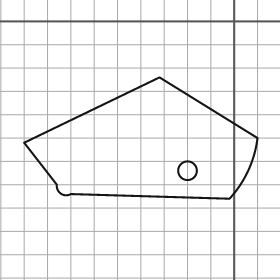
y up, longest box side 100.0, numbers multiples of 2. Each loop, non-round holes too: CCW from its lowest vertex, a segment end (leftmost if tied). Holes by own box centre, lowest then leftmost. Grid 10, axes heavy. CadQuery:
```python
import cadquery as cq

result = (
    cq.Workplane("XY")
    .moveTo(-2.0, -76.0)
    .threePointArc((6.0, -64.0), (10.0, -50.0))
    .lineTo(-32.0, -24.0)
    .lineTo(-90.0, -52.0)
    .lineTo(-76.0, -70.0)
    .threePointArc((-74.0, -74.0), (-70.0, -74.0))
    .close()
    .moveTo(-20.0, -64.0)
    .circle(4.0)
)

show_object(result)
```